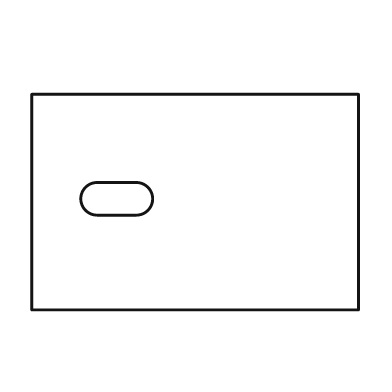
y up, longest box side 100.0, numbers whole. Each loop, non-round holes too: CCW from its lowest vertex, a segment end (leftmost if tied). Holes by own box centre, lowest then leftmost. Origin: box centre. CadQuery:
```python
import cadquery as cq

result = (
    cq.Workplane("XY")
    .moveTo(-50.0, -33.0)
    .lineTo(50.0, -33.0)
    .lineTo(50.0, 33.0)
    .lineTo(-50.0, 33.0)
    .close()
    .moveTo(-30.0, -4.0)
    .lineTo(-18.0, -4.0)
    .threePointArc((-13.0, 1.0), (-18.0, 6.0))
    .lineTo(-30.0, 6.0)
    .threePointArc((-35.0, 1.0), (-30.0, -4.0))
    .close()
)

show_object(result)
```